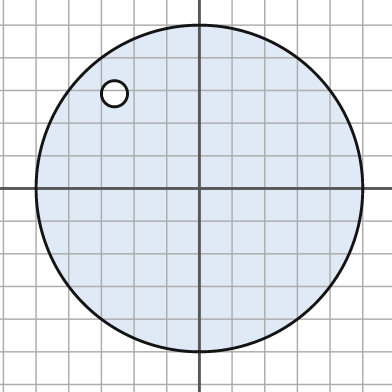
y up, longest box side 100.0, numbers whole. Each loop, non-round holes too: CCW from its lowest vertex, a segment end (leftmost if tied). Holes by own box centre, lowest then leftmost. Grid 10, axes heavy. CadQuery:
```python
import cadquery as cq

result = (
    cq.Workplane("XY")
    .moveTo(0.0, 0.0)
    .circle(50.0)
    .moveTo(-26.0, 29.0)
    .circle(4.0)
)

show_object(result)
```